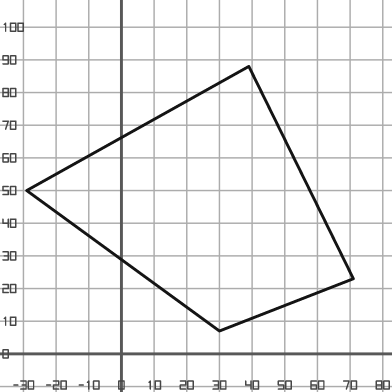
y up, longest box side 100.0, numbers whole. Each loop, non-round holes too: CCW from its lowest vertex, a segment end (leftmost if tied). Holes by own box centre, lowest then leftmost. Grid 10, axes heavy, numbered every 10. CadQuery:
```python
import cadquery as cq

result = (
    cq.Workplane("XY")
    .moveTo(30.0, 7.0)
    .lineTo(71.0, 23.0)
    .lineTo(39.0, 88.0)
    .lineTo(-29.0, 50.0)
    .close()
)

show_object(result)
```